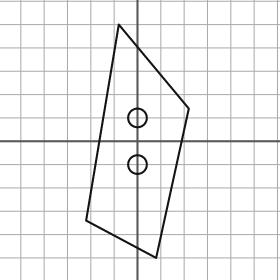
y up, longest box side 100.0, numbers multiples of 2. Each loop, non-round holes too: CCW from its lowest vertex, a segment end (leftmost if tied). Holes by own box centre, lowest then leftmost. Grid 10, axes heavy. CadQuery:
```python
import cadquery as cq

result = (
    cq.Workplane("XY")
    .moveTo(8.0, -50.0)
    .lineTo(22.0, 14.0)
    .lineTo(-8.0, 50.0)
    .lineTo(-22.0, -34.0)
    .close()
    .moveTo(0.0, -10.0)
    .circle(4.0)
    .moveTo(0.0, 10.0)
    .circle(4.0)
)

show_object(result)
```